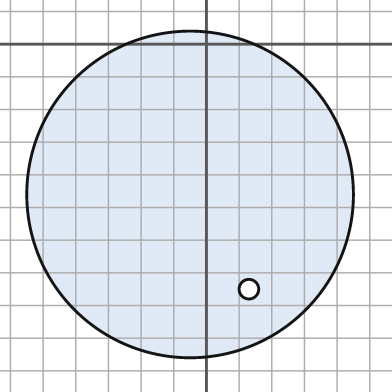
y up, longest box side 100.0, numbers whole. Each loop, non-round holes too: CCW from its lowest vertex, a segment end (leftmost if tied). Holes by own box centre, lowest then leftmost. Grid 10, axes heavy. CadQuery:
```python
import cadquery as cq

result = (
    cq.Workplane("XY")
    .moveTo(-5.0, -46.0)
    .circle(50.0)
    .moveTo(13.0, -75.0)
    .circle(3.0)
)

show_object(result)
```